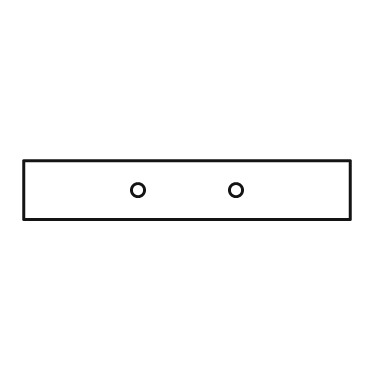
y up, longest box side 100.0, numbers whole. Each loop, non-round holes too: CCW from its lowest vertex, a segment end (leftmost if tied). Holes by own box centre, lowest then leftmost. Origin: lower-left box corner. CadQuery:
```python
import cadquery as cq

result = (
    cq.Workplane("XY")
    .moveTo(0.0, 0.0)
    .lineTo(100.0, 0.0)
    .lineTo(100.0, 18.0)
    .lineTo(0.0, 18.0)
    .close()
    .moveTo(35.0, 9.0)
    .circle(2.0)
    .moveTo(65.0, 9.0)
    .circle(2.0)
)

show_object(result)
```